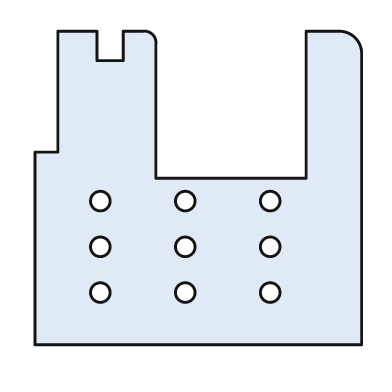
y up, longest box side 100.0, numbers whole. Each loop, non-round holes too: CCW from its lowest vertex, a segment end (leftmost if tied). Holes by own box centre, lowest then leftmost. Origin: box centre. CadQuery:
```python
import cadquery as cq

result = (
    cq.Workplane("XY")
    .moveTo(-50.0, -48.0)
    .lineTo(50.0, -48.0)
    .lineTo(50.0, 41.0)
    .threePointArc((48.0, 46.0), (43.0, 48.0))
    .lineTo(33.0, 48.0)
    .lineTo(33.0, 3.0)
    .lineTo(-13.0, 3.0)
    .lineTo(-13.0, 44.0)
    .threePointArc((-14.0, 47.0), (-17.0, 48.0))
    .lineTo(-23.0, 48.0)
    .lineTo(-23.0, 39.0)
    .lineTo(-31.0, 39.0)
    .lineTo(-31.0, 48.0)
    .lineTo(-43.0, 48.0)
    .lineTo(-43.0, 11.0)
    .lineTo(-50.0, 11.0)
    .close()
    .moveTo(-30.0, -32.0)
    .circle(3.0)
    .moveTo(-4.0, -32.0)
    .circle(3.0)
    .moveTo(22.0, -32.0)
    .circle(3.0)
    .moveTo(-30.0, -18.0)
    .circle(3.0)
    .moveTo(-4.0, -18.0)
    .circle(3.0)
    .moveTo(22.0, -18.0)
    .circle(3.0)
    .moveTo(-30.0, -4.0)
    .circle(3.0)
    .moveTo(-4.0, -4.0)
    .circle(3.0)
    .moveTo(22.0, -4.0)
    .circle(3.0)
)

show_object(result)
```